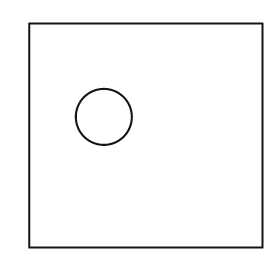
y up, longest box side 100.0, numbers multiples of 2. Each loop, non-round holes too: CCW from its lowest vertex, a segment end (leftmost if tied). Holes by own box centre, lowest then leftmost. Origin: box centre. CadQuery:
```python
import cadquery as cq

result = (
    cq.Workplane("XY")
    .moveTo(-50.0, -48.0)
    .lineTo(50.0, -48.0)
    .lineTo(50.0, 48.0)
    .lineTo(-50.0, 48.0)
    .close()
    .moveTo(-18.0, 8.0)
    .circle(12.0)
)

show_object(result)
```